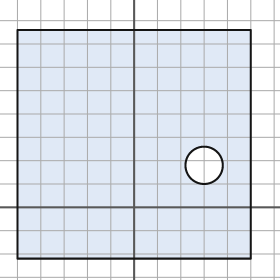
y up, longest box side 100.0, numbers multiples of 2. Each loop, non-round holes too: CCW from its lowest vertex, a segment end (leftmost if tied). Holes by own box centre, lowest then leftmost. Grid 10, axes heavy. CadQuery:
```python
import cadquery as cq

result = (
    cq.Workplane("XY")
    .moveTo(-50.0, -22.0)
    .lineTo(50.0, -22.0)
    .lineTo(50.0, 76.0)
    .lineTo(-50.0, 76.0)
    .close()
    .moveTo(30.0, 18.0)
    .circle(8.0)
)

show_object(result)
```